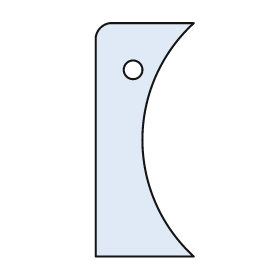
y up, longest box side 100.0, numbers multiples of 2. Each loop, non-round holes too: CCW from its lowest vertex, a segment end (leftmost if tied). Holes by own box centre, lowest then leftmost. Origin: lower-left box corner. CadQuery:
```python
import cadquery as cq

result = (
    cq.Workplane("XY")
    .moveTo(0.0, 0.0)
    .lineTo(42.0, 0.0)
    .threePointArc((20.0, 50.0), (42.0, 100.0))
    .lineTo(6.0, 100.0)
    .threePointArc((2.0, 98.0), (0.0, 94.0))
    .close()
    .moveTo(16.0, 80.0)
    .circle(4.0)
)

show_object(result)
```